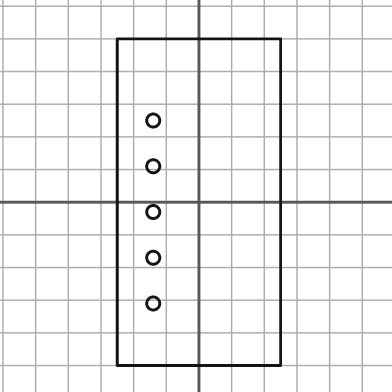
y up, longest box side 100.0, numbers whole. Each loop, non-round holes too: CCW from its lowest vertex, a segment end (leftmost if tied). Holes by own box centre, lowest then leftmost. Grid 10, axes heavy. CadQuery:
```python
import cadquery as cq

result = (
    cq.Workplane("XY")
    .moveTo(-25.0, -50.0)
    .lineTo(25.0, -50.0)
    .lineTo(25.0, 50.0)
    .lineTo(-25.0, 50.0)
    .close()
    .moveTo(-14.0, -31.0)
    .circle(2.0)
    .moveTo(-14.0, -17.0)
    .circle(2.0)
    .moveTo(-14.0, -3.0)
    .circle(2.0)
    .moveTo(-14.0, 11.0)
    .circle(2.0)
    .moveTo(-14.0, 25.0)
    .circle(2.0)
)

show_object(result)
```